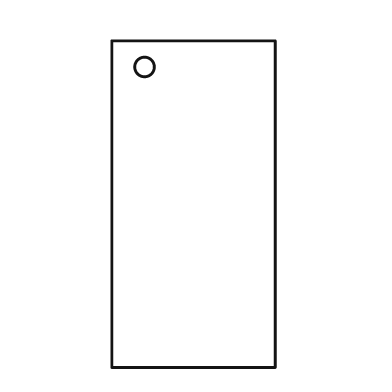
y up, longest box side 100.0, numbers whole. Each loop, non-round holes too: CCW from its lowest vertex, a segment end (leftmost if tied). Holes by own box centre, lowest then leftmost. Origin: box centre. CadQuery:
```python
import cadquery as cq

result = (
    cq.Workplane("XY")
    .moveTo(-25.0, -50.0)
    .lineTo(25.0, -50.0)
    .lineTo(25.0, 50.0)
    .lineTo(-25.0, 50.0)
    .close()
    .moveTo(-15.0, 42.0)
    .circle(3.0)
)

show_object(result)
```